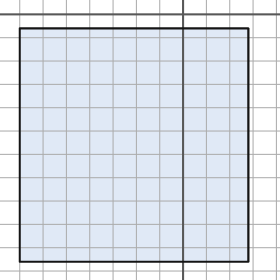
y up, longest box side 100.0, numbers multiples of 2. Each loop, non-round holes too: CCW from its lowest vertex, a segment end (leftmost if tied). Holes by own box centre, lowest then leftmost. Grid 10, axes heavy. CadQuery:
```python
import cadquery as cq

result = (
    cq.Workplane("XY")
    .moveTo(-70.0, -106.0)
    .lineTo(28.0, -106.0)
    .lineTo(28.0, -6.0)
    .lineTo(-70.0, -6.0)
    .close()
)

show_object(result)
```